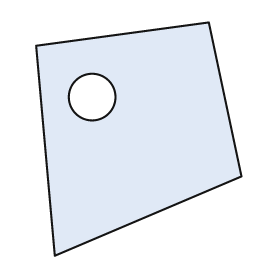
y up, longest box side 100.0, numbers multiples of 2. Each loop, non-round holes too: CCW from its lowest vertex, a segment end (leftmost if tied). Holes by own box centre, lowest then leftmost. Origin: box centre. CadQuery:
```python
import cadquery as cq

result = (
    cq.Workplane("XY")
    .moveTo(-36.0, -50.0)
    .lineTo(44.0, -16.0)
    .lineTo(30.0, 50.0)
    .lineTo(-44.0, 40.0)
    .close()
    .moveTo(-20.0, 18.0)
    .circle(10.0)
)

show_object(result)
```